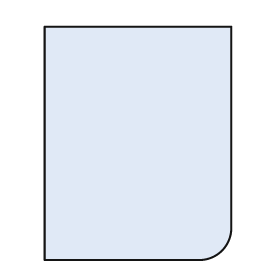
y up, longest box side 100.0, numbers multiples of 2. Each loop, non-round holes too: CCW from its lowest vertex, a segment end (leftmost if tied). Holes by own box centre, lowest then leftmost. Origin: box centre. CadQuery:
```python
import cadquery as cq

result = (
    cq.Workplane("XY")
    .moveTo(-40.0, -50.0)
    .lineTo(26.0, -50.0)
    .threePointArc((36.0, -46.0), (40.0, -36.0))
    .lineTo(40.0, 50.0)
    .lineTo(-40.0, 50.0)
    .close()
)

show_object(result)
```